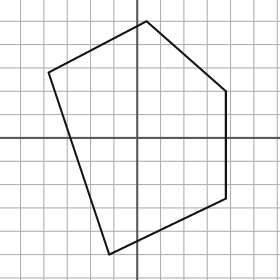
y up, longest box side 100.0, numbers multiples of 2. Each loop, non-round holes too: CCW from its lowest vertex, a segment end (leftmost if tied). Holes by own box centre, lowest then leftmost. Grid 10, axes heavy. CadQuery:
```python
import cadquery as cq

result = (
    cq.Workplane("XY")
    .moveTo(-12.0, -50.0)
    .lineTo(38.0, -26.0)
    .lineTo(38.0, 20.0)
    .lineTo(4.0, 50.0)
    .lineTo(-38.0, 28.0)
    .close()
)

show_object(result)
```